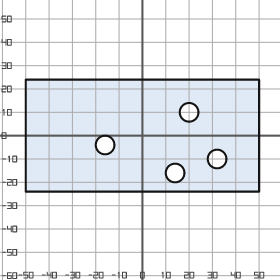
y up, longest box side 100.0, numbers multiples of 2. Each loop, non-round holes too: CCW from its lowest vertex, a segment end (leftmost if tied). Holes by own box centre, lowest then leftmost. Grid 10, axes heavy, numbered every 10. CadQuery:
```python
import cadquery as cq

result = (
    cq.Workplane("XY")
    .moveTo(-50.0, -24.0)
    .lineTo(50.0, -24.0)
    .lineTo(50.0, 24.0)
    .lineTo(-50.0, 24.0)
    .close()
    .moveTo(14.0, -16.0)
    .circle(4.0)
    .moveTo(32.0, -10.0)
    .circle(4.0)
    .moveTo(-16.0, -4.0)
    .circle(4.0)
    .moveTo(20.0, 10.0)
    .circle(4.0)
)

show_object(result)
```